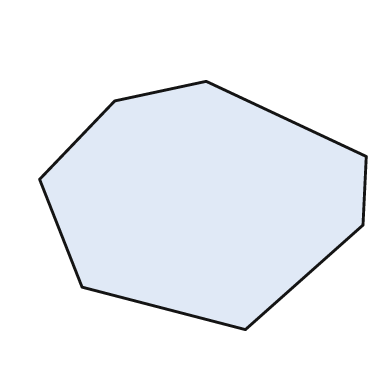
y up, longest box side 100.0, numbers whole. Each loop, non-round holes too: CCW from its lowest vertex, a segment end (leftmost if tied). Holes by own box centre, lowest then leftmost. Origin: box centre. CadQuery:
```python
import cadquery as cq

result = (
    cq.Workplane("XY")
    .moveTo(13.0, -38.0)
    .lineTo(49.0, -6.0)
    .lineTo(50.0, 15.0)
    .lineTo(1.0, 38.0)
    .lineTo(-27.0, 32.0)
    .lineTo(-50.0, 8.0)
    .lineTo(-37.0, -25.0)
    .close()
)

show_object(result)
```